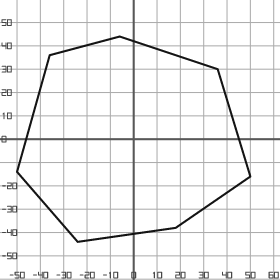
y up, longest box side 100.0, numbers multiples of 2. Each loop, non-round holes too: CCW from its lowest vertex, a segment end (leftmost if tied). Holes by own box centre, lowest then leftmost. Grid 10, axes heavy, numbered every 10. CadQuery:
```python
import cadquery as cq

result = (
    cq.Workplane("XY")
    .moveTo(-24.0, -44.0)
    .lineTo(18.0, -38.0)
    .lineTo(50.0, -16.0)
    .lineTo(36.0, 30.0)
    .lineTo(-6.0, 44.0)
    .lineTo(-36.0, 36.0)
    .lineTo(-50.0, -14.0)
    .close()
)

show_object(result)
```